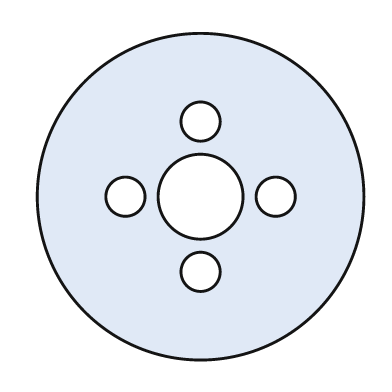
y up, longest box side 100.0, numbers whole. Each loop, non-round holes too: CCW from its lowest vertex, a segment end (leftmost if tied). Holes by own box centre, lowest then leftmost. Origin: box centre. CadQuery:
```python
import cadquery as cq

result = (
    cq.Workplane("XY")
    .moveTo(0.0, 0.0)
    .circle(50.0)
    .moveTo(0.0, -23.0)
    .circle(6.0)
    .moveTo(-23.0, 0.0)
    .circle(6.0)
    .moveTo(0.0, 0.0)
    .circle(13.0)
    .moveTo(23.0, 0.0)
    .circle(6.0)
    .moveTo(0.0, 23.0)
    .circle(6.0)
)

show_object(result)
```